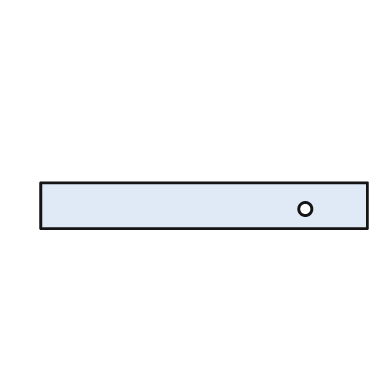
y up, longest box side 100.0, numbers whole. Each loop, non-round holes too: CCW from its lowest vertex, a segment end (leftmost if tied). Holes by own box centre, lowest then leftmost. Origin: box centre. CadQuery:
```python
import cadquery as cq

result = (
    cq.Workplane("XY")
    .moveTo(-50.0, -7.0)
    .lineTo(50.0, -7.0)
    .lineTo(50.0, 7.0)
    .lineTo(-50.0, 7.0)
    .close()
    .moveTo(31.0, -1.0)
    .circle(2.0)
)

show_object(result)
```